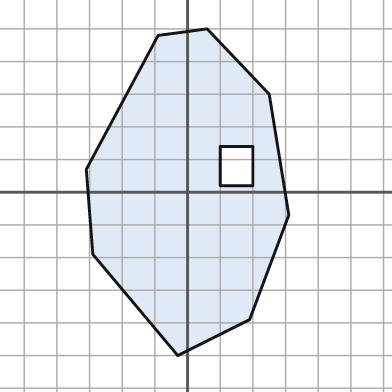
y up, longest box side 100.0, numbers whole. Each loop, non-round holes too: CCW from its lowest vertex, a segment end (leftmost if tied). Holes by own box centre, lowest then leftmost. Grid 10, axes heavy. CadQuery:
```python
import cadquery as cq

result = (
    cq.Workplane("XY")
    .moveTo(-3.0, -50.0)
    .lineTo(19.0, -39.0)
    .lineTo(31.0, -7.0)
    .lineTo(25.0, 30.0)
    .lineTo(6.0, 50.0)
    .lineTo(-9.0, 48.0)
    .lineTo(-31.0, 7.0)
    .lineTo(-29.0, -19.0)
    .close()
    .moveTo(10.0, 2.0)
    .lineTo(20.0, 2.0)
    .lineTo(20.0, 14.0)
    .lineTo(10.0, 14.0)
    .close()
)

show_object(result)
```